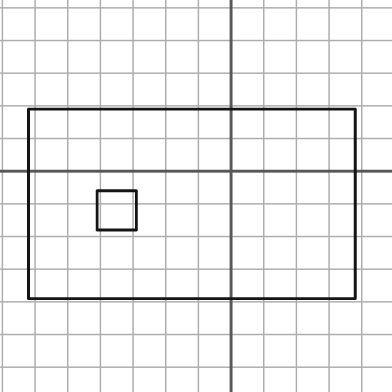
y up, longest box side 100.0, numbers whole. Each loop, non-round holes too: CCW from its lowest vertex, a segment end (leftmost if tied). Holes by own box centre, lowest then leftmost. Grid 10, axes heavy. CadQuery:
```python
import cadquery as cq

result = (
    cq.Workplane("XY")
    .moveTo(-62.0, -39.0)
    .lineTo(38.0, -39.0)
    .lineTo(38.0, 19.0)
    .lineTo(-62.0, 19.0)
    .close()
    .moveTo(-41.0, -18.0)
    .lineTo(-29.0, -18.0)
    .lineTo(-29.0, -6.0)
    .lineTo(-41.0, -6.0)
    .close()
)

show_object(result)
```